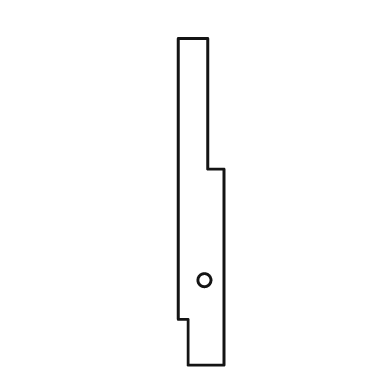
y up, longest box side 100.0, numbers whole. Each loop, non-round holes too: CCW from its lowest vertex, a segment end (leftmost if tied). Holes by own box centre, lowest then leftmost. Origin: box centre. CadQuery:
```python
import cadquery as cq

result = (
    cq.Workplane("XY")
    .moveTo(-4.0, -50.0)
    .lineTo(7.0, -50.0)
    .lineTo(7.0, 10.0)
    .lineTo(2.0, 10.0)
    .lineTo(2.0, 50.0)
    .lineTo(-7.0, 50.0)
    .lineTo(-7.0, -36.0)
    .lineTo(-4.0, -36.0)
    .close()
    .moveTo(1.0, -24.0)
    .circle(2.0)
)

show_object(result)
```